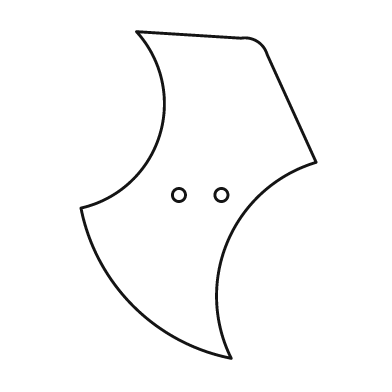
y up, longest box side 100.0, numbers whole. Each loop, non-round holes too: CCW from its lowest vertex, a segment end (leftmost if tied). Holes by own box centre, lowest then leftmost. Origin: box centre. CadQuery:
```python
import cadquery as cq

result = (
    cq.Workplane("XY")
    .moveTo(10.0, -50.0)
    .threePointArc((9.0, -14.0), (36.0, 10.0))
    .lineTo(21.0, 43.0)
    .threePointArc((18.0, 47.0), (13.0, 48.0))
    .lineTo(-19.0, 50.0)
    .threePointArc((-12.0, 18.0), (-36.0, -4.0))
    .threePointArc((-20.0, -34.0), (10.0, -50.0))
    .close()
    .moveTo(-6.0, 0.0)
    .circle(2.0)
    .moveTo(7.0, 0.0)
    .circle(2.0)
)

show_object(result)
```